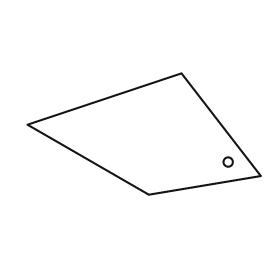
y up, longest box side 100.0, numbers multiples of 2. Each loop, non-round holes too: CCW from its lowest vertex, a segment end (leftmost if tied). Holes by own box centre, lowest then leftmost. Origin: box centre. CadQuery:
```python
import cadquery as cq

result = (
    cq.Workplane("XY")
    .moveTo(2.0, -26.0)
    .lineTo(50.0, -18.0)
    .lineTo(16.0, 26.0)
    .lineTo(-50.0, 4.0)
    .close()
    .moveTo(36.0, -12.0)
    .circle(2.0)
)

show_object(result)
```